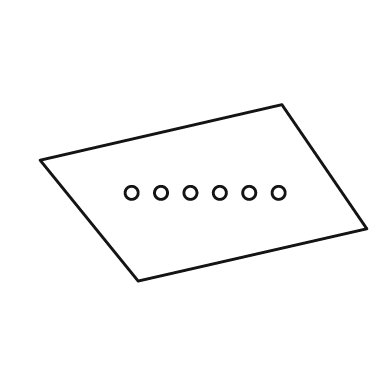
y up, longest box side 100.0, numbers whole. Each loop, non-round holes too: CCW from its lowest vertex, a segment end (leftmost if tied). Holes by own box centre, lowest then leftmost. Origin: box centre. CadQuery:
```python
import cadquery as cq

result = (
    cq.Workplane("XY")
    .moveTo(-20.0, -27.0)
    .lineTo(50.0, -11.0)
    .lineTo(24.0, 27.0)
    .lineTo(-50.0, 10.0)
    .close()
    .moveTo(-22.0, 0.0)
    .circle(2.0)
    .moveTo(-13.0, 0.0)
    .circle(2.0)
    .moveTo(-4.0, 0.0)
    .circle(2.0)
    .moveTo(5.0, 0.0)
    .circle(2.0)
    .moveTo(14.0, 0.0)
    .circle(2.0)
    .moveTo(23.0, 0.0)
    .circle(2.0)
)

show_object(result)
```